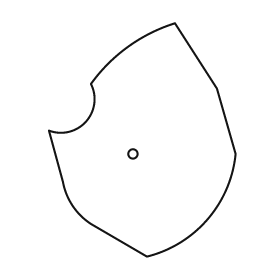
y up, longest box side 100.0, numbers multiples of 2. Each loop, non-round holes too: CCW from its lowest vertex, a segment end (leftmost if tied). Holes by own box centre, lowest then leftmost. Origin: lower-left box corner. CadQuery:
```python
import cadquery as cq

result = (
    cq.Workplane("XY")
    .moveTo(42.0, 0.0)
    .threePointArc((68.0, 16.0), (80.0, 44.0))
    .lineTo(72.0, 72.0)
    .lineTo(54.0, 100.0)
    .threePointArc((34.0, 90.0), (18.0, 74.0))
    .threePointArc((16.0, 58.0), (0.0, 54.0))
    .lineTo(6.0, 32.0)
    .threePointArc((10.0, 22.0), (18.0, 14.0))
    .close()
    .moveTo(36.0, 44.0)
    .circle(2.0)
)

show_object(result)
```